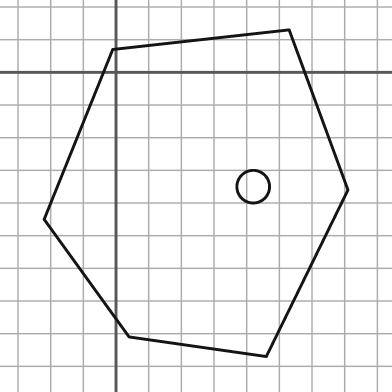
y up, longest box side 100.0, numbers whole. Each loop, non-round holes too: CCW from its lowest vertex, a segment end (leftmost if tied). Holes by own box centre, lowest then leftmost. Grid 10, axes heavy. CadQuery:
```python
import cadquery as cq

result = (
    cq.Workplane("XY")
    .moveTo(46.0, -87.0)
    .lineTo(71.0, -36.0)
    .lineTo(53.0, 13.0)
    .lineTo(-1.0, 7.0)
    .lineTo(-22.0, -45.0)
    .lineTo(4.0, -81.0)
    .close()
    .moveTo(42.0, -35.0)
    .circle(5.0)
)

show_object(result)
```